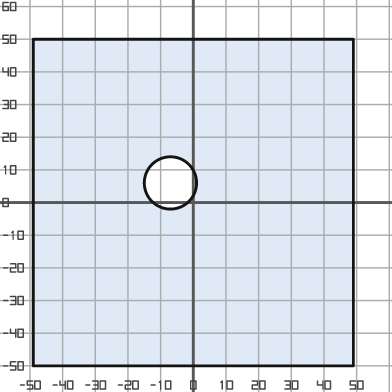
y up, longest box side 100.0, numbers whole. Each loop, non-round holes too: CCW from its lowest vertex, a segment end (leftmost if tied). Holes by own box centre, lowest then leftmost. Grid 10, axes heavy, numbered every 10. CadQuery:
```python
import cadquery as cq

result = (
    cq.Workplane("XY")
    .moveTo(-49.0, -50.0)
    .lineTo(49.0, -50.0)
    .lineTo(49.0, 50.0)
    .lineTo(-49.0, 50.0)
    .close()
    .moveTo(-7.0, 6.0)
    .circle(8.0)
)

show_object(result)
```